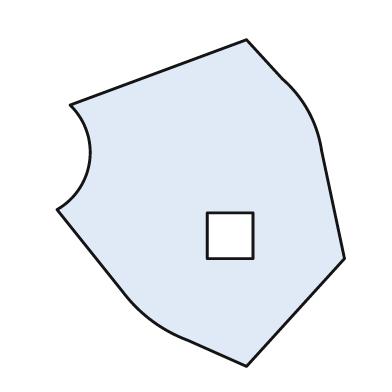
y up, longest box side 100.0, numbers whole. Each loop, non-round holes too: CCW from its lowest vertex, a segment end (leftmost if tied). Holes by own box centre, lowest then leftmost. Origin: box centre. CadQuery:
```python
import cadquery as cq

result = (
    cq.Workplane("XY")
    .moveTo(14.0, -50.0)
    .lineTo(44.0, -17.0)
    .lineTo(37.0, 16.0)
    .threePointArc((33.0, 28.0), (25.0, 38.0))
    .lineTo(14.0, 50.0)
    .lineTo(-40.0, 30.0)
    .threePointArc((-34.0, 13.0), (-44.0, -2.0))
    .lineTo(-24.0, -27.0)
    .threePointArc((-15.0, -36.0), (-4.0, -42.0))
    .close()
    .moveTo(2.0, -17.0)
    .lineTo(16.0, -17.0)
    .lineTo(16.0, -3.0)
    .lineTo(2.0, -3.0)
    .close()
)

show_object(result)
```